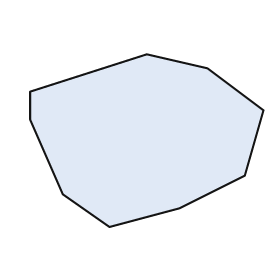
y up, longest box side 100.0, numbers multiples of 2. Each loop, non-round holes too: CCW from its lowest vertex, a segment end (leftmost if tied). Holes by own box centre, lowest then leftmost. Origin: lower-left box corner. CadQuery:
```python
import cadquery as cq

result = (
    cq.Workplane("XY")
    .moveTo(34.0, 0.0)
    .lineTo(64.0, 8.0)
    .lineTo(92.0, 22.0)
    .lineTo(100.0, 50.0)
    .lineTo(76.0, 68.0)
    .lineTo(50.0, 74.0)
    .lineTo(0.0, 58.0)
    .lineTo(0.0, 46.0)
    .lineTo(14.0, 14.0)
    .close()
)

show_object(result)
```